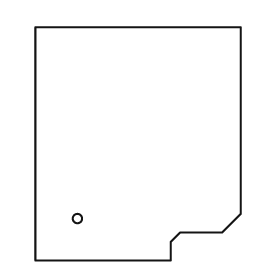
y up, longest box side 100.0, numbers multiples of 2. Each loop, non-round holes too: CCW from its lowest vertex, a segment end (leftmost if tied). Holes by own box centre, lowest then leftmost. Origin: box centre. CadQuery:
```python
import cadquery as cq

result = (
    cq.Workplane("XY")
    .moveTo(-44.0, -50.0)
    .lineTo(14.0, -50.0)
    .lineTo(14.0, -42.0)
    .lineTo(18.0, -38.0)
    .lineTo(36.0, -38.0)
    .lineTo(44.0, -30.0)
    .lineTo(44.0, 50.0)
    .lineTo(-44.0, 50.0)
    .close()
    .moveTo(-26.0, -32.0)
    .circle(2.0)
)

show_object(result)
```